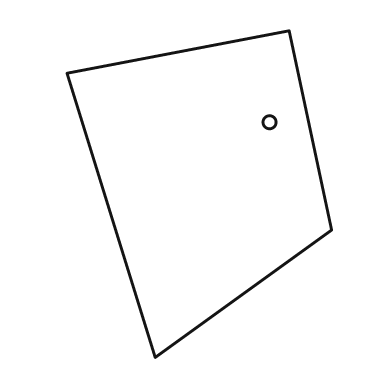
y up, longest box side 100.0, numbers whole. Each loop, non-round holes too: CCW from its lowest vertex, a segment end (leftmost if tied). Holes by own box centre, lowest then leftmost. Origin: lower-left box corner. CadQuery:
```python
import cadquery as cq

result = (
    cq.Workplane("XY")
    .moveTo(27.0, 0.0)
    .lineTo(81.0, 39.0)
    .lineTo(68.0, 100.0)
    .lineTo(0.0, 87.0)
    .close()
    .moveTo(62.0, 72.0)
    .circle(2.0)
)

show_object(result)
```